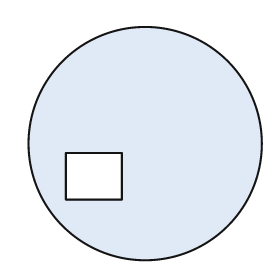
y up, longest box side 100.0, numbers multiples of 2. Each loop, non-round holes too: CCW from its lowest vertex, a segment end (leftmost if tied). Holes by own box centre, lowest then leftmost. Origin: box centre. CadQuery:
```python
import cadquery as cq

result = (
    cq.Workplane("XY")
    .moveTo(0.0, 0.0)
    .circle(50.0)
    .moveTo(-34.0, -24.0)
    .lineTo(-10.0, -24.0)
    .lineTo(-10.0, -4.0)
    .lineTo(-34.0, -4.0)
    .close()
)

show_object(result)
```